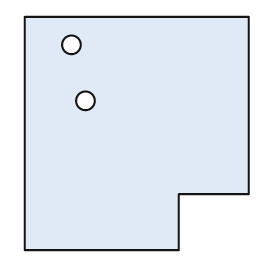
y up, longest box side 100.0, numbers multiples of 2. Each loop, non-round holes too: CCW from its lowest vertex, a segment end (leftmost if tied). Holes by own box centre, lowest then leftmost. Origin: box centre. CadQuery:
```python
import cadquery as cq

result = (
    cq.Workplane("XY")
    .moveTo(-48.0, -50.0)
    .lineTo(18.0, -50.0)
    .lineTo(18.0, -26.0)
    .lineTo(48.0, -26.0)
    .lineTo(48.0, 50.0)
    .lineTo(-48.0, 50.0)
    .close()
    .moveTo(-22.0, 14.0)
    .circle(4.0)
    .moveTo(-28.0, 38.0)
    .circle(4.0)
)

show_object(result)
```